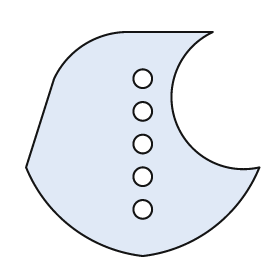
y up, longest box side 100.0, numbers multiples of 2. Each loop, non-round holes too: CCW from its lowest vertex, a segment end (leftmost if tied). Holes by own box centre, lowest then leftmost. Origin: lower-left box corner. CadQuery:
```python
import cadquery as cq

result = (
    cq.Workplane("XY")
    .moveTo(50.0, 0.0)
    .threePointArc((80.0, 12.0), (100.0, 38.0))
    .threePointArc((64.0, 58.0), (80.0, 96.0))
    .lineTo(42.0, 96.0)
    .threePointArc((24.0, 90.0), (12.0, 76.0))
    .lineTo(0.0, 38.0)
    .threePointArc((20.0, 12.0), (50.0, 0.0))
    .close()
    .moveTo(50.0, 20.0)
    .circle(4.0)
    .moveTo(50.0, 34.0)
    .circle(4.0)
    .moveTo(50.0, 48.0)
    .circle(4.0)
    .moveTo(50.0, 62.0)
    .circle(4.0)
    .moveTo(50.0, 76.0)
    .circle(4.0)
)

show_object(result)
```